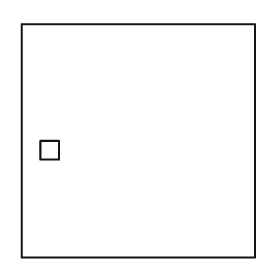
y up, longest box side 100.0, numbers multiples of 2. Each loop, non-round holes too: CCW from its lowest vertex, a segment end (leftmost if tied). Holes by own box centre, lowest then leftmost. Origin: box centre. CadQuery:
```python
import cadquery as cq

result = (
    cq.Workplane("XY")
    .moveTo(-50.0, -50.0)
    .lineTo(50.0, -50.0)
    .lineTo(50.0, 50.0)
    .lineTo(-50.0, 50.0)
    .close()
    .moveTo(-42.0, -8.0)
    .lineTo(-34.0, -8.0)
    .lineTo(-34.0, 0.0)
    .lineTo(-42.0, 0.0)
    .close()
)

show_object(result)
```